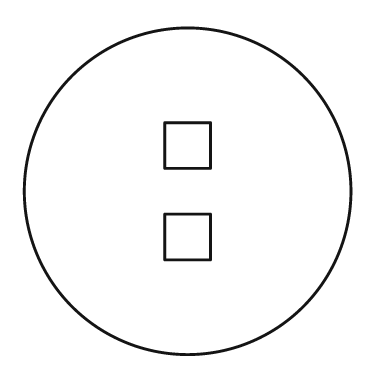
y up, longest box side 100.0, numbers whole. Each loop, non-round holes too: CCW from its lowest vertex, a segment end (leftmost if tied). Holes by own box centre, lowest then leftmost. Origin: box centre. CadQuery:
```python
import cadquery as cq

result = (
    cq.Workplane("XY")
    .moveTo(0.0, 0.0)
    .circle(50.0)
    .moveTo(-7.0, -21.0)
    .lineTo(7.0, -21.0)
    .lineTo(7.0, -7.0)
    .lineTo(-7.0, -7.0)
    .close()
    .moveTo(-7.0, 7.0)
    .lineTo(7.0, 7.0)
    .lineTo(7.0, 21.0)
    .lineTo(-7.0, 21.0)
    .close()
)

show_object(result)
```